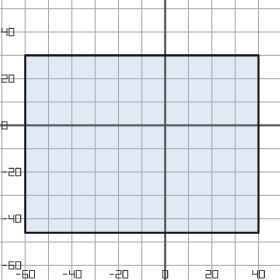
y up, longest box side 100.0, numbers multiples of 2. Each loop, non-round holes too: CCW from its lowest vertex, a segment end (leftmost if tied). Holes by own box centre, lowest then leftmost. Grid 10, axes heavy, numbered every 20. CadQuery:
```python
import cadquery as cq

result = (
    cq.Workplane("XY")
    .moveTo(-60.0, -46.0)
    .lineTo(40.0, -46.0)
    .lineTo(40.0, 30.0)
    .lineTo(-60.0, 30.0)
    .close()
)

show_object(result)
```